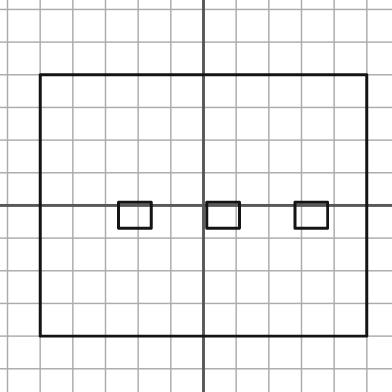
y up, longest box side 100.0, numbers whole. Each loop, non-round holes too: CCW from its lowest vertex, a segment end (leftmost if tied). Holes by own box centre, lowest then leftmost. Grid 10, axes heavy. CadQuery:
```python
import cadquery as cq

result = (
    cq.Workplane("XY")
    .moveTo(-50.0, -40.0)
    .lineTo(50.0, -40.0)
    .lineTo(50.0, 40.0)
    .lineTo(-50.0, 40.0)
    .close()
    .moveTo(-26.0, -7.0)
    .lineTo(-16.0, -7.0)
    .lineTo(-16.0, 1.0)
    .lineTo(-26.0, 1.0)
    .close()
    .moveTo(1.0, -7.0)
    .lineTo(11.0, -7.0)
    .lineTo(11.0, 1.0)
    .lineTo(1.0, 1.0)
    .close()
    .moveTo(28.0, -7.0)
    .lineTo(38.0, -7.0)
    .lineTo(38.0, 1.0)
    .lineTo(28.0, 1.0)
    .close()
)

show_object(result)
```